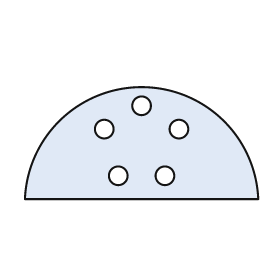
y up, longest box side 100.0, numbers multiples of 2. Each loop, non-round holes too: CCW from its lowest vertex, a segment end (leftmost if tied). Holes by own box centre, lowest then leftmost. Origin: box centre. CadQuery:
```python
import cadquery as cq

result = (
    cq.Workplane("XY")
    .moveTo(-50.0, -24.0)
    .lineTo(50.0, -24.0)
    .threePointArc((0.0, 24.0), (-50.0, -24.0))
    .close()
    .moveTo(-10.0, -14.0)
    .circle(4.0)
    .moveTo(10.0, -14.0)
    .circle(4.0)
    .moveTo(-16.0, 6.0)
    .circle(4.0)
    .moveTo(16.0, 6.0)
    .circle(4.0)
    .moveTo(0.0, 16.0)
    .circle(4.0)
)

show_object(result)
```